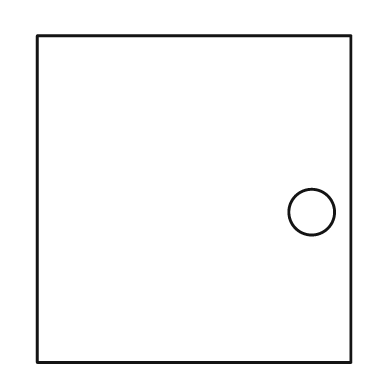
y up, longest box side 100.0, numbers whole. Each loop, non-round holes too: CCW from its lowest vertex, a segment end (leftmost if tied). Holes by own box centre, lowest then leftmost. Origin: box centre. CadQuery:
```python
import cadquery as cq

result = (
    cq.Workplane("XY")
    .moveTo(-48.0, -50.0)
    .lineTo(48.0, -50.0)
    .lineTo(48.0, 50.0)
    .lineTo(-48.0, 50.0)
    .close()
    .moveTo(36.0, -4.0)
    .circle(7.0)
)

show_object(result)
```